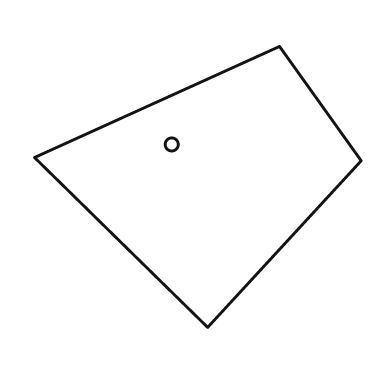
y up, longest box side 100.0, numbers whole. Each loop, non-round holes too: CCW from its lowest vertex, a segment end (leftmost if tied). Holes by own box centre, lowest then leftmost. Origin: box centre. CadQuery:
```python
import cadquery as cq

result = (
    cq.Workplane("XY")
    .moveTo(3.0, -43.0)
    .lineTo(50.0, 8.0)
    .lineTo(25.0, 43.0)
    .lineTo(-50.0, 9.0)
    .close()
    .moveTo(-8.0, 13.0)
    .circle(2.0)
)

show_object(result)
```